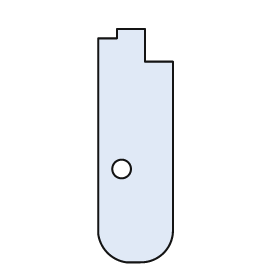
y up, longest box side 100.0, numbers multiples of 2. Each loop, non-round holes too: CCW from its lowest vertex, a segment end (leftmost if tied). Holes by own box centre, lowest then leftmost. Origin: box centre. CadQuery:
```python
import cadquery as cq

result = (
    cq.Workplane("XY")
    .moveTo(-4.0, -50.0)
    .lineTo(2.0, -50.0)
    .threePointArc((12.0, -46.0), (16.0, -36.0))
    .lineTo(16.0, 36.0)
    .lineTo(4.0, 36.0)
    .lineTo(4.0, 50.0)
    .lineTo(-8.0, 50.0)
    .lineTo(-8.0, 46.0)
    .lineTo(-16.0, 46.0)
    .lineTo(-16.0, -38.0)
    .threePointArc((-12.0, -46.0), (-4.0, -50.0))
    .close()
    .moveTo(-6.0, -10.0)
    .circle(4.0)
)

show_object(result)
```